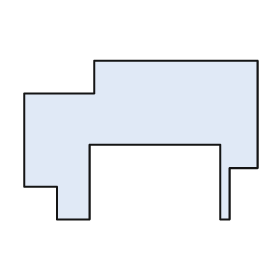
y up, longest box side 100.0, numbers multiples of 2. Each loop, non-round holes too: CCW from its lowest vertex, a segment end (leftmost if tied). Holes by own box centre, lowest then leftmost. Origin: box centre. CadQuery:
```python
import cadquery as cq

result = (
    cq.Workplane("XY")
    .moveTo(-36.0, -34.0)
    .lineTo(-22.0, -34.0)
    .lineTo(-22.0, -2.0)
    .lineTo(34.0, -2.0)
    .lineTo(34.0, -34.0)
    .lineTo(38.0, -34.0)
    .lineTo(38.0, -12.0)
    .lineTo(50.0, -12.0)
    .lineTo(50.0, 34.0)
    .lineTo(-20.0, 34.0)
    .lineTo(-20.0, 20.0)
    .lineTo(-50.0, 20.0)
    .lineTo(-50.0, -20.0)
    .lineTo(-36.0, -20.0)
    .close()
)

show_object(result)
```